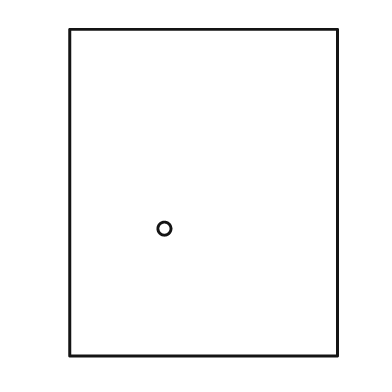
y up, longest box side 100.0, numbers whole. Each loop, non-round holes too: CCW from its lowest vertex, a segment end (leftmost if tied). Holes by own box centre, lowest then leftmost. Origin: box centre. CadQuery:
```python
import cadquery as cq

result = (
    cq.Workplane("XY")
    .moveTo(-41.0, -50.0)
    .lineTo(41.0, -50.0)
    .lineTo(41.0, 50.0)
    .lineTo(-41.0, 50.0)
    .close()
    .moveTo(-12.0, -11.0)
    .circle(2.0)
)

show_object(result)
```